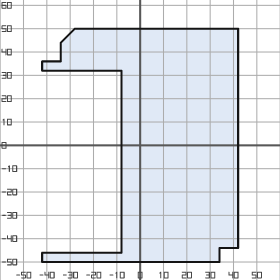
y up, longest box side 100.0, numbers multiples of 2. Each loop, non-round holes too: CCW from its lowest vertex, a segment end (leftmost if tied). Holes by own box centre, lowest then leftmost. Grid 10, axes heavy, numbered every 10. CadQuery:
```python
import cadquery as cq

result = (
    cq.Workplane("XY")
    .moveTo(-42.0, -50.0)
    .lineTo(34.0, -50.0)
    .lineTo(34.0, -44.0)
    .lineTo(42.0, -44.0)
    .lineTo(42.0, 50.0)
    .lineTo(-28.0, 50.0)
    .lineTo(-34.0, 44.0)
    .lineTo(-34.0, 36.0)
    .lineTo(-42.0, 36.0)
    .lineTo(-42.0, 32.0)
    .lineTo(-8.0, 32.0)
    .lineTo(-8.0, -46.0)
    .lineTo(-42.0, -46.0)
    .close()
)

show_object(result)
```